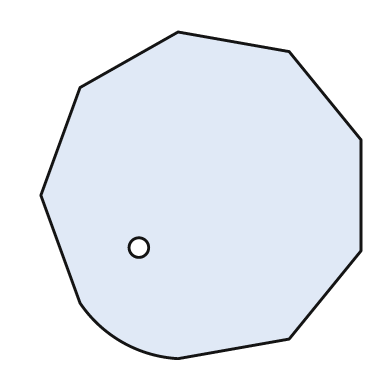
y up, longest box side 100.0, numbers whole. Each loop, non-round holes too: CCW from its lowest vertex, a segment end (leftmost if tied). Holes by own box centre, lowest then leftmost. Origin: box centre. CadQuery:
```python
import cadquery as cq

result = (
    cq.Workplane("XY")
    .moveTo(-7.0, -50.0)
    .lineTo(27.0, -44.0)
    .lineTo(49.0, -17.0)
    .lineTo(49.0, 17.0)
    .lineTo(27.0, 44.0)
    .lineTo(-7.0, 50.0)
    .lineTo(-37.0, 33.0)
    .lineTo(-49.0, 0.0)
    .lineTo(-37.0, -33.0)
    .threePointArc((-24.0, -45.0), (-7.0, -50.0))
    .close()
    .moveTo(-19.0, -16.0)
    .circle(3.0)
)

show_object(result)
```